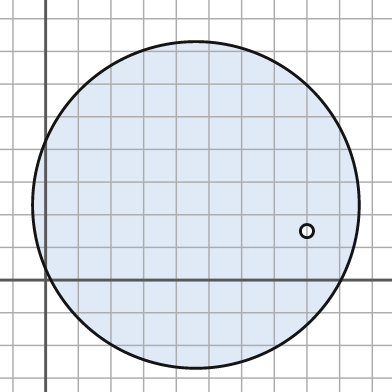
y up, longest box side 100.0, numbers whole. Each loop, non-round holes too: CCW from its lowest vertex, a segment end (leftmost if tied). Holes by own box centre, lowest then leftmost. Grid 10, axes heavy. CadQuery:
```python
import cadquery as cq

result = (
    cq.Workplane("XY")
    .moveTo(46.0, 23.0)
    .circle(50.0)
    .moveTo(80.0, 15.0)
    .circle(2.0)
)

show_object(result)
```